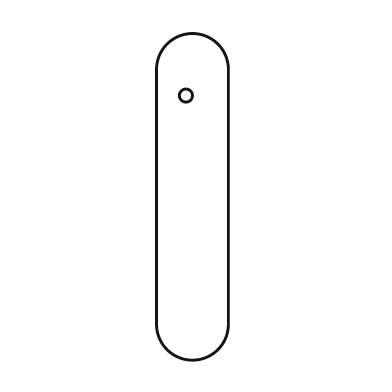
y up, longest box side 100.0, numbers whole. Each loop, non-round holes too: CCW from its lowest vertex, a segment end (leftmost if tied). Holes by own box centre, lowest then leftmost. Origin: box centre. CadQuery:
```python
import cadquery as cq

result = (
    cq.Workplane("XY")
    .moveTo(-11.0, -39.0)
    .threePointArc((0.0, -50.0), (11.0, -39.0))
    .lineTo(11.0, 39.0)
    .threePointArc((0.0, 50.0), (-11.0, 39.0))
    .close()
    .moveTo(-2.0, 31.0)
    .circle(2.0)
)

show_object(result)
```